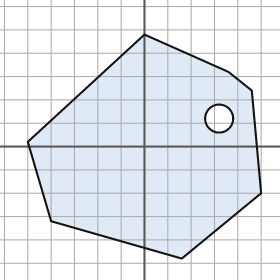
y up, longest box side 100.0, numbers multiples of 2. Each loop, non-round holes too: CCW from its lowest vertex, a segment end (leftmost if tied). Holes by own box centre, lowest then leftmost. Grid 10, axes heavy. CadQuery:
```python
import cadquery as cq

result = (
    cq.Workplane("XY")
    .moveTo(16.0, -48.0)
    .lineTo(50.0, -20.0)
    .lineTo(46.0, 24.0)
    .lineTo(36.0, 32.0)
    .lineTo(0.0, 48.0)
    .lineTo(-50.0, 2.0)
    .lineTo(-40.0, -32.0)
    .close()
    .moveTo(32.0, 12.0)
    .circle(6.0)
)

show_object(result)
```